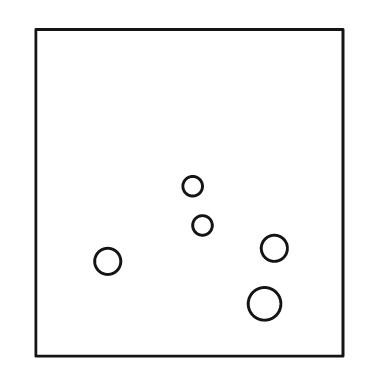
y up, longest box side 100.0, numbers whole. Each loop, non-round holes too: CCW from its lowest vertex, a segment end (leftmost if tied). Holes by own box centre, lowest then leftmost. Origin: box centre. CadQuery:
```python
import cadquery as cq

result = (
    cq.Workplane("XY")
    .moveTo(-47.0, -50.0)
    .lineTo(47.0, -50.0)
    .lineTo(47.0, 50.0)
    .lineTo(-47.0, 50.0)
    .close()
    .moveTo(23.0, -34.0)
    .circle(5.0)
    .moveTo(-25.0, -21.0)
    .circle(4.0)
    .moveTo(26.0, -17.0)
    .circle(4.0)
    .moveTo(4.0, -10.0)
    .circle(3.0)
    .moveTo(1.0, 2.0)
    .circle(3.0)
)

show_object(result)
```